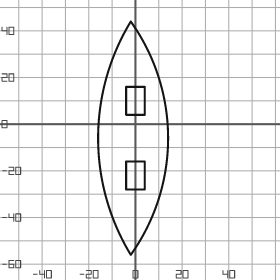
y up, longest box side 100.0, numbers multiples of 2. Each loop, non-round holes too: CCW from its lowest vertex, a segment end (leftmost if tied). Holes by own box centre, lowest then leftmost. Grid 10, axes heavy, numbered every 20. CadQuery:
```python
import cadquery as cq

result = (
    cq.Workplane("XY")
    .moveTo(-2.0, -56.0)
    .threePointArc((14.0, -6.0), (-2.0, 44.0))
    .threePointArc((-16.0, -6.0), (-2.0, -56.0))
    .close()
    .moveTo(-4.0, -28.0)
    .lineTo(4.0, -28.0)
    .lineTo(4.0, -16.0)
    .lineTo(-4.0, -16.0)
    .close()
    .moveTo(-4.0, 4.0)
    .lineTo(4.0, 4.0)
    .lineTo(4.0, 16.0)
    .lineTo(-4.0, 16.0)
    .close()
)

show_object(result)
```